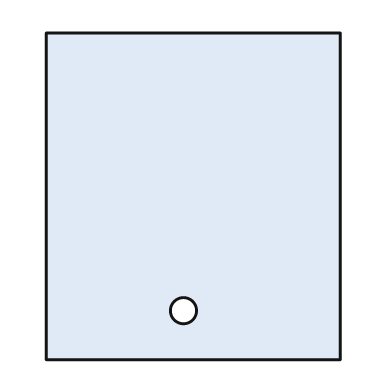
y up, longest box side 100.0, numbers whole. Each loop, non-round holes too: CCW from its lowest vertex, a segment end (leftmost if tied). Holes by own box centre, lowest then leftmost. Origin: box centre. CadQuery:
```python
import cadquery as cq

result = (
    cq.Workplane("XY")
    .moveTo(-45.0, -50.0)
    .lineTo(45.0, -50.0)
    .lineTo(45.0, 50.0)
    .lineTo(-45.0, 50.0)
    .close()
    .moveTo(-3.0, -35.0)
    .circle(4.0)
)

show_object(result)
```